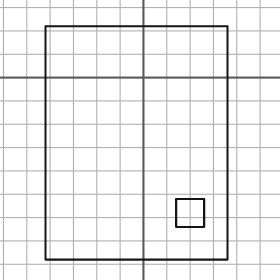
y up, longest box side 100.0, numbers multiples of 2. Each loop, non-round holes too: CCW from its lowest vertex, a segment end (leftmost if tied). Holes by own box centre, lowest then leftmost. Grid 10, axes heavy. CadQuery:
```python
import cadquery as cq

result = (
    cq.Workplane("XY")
    .moveTo(-42.0, -78.0)
    .lineTo(36.0, -78.0)
    .lineTo(36.0, 22.0)
    .lineTo(-42.0, 22.0)
    .close()
    .moveTo(14.0, -64.0)
    .lineTo(26.0, -64.0)
    .lineTo(26.0, -52.0)
    .lineTo(14.0, -52.0)
    .close()
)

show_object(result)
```